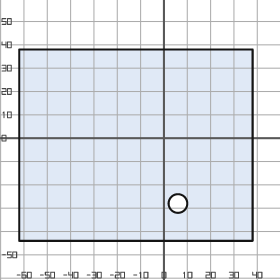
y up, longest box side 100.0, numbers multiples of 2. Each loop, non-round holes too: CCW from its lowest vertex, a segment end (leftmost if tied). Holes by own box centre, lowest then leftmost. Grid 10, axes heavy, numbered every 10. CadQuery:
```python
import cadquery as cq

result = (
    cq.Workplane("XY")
    .moveTo(-62.0, -44.0)
    .lineTo(38.0, -44.0)
    .lineTo(38.0, 38.0)
    .lineTo(-62.0, 38.0)
    .close()
    .moveTo(6.0, -28.0)
    .circle(4.0)
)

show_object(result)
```